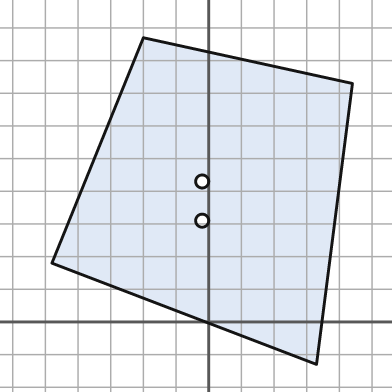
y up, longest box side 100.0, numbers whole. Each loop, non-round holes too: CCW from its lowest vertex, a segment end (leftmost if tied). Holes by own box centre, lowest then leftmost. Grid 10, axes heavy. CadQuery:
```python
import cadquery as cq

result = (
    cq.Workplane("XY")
    .moveTo(33.0, -13.0)
    .lineTo(44.0, 73.0)
    .lineTo(-20.0, 87.0)
    .lineTo(-48.0, 18.0)
    .close()
    .moveTo(-2.0, 31.0)
    .circle(2.0)
    .moveTo(-2.0, 43.0)
    .circle(2.0)
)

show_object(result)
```